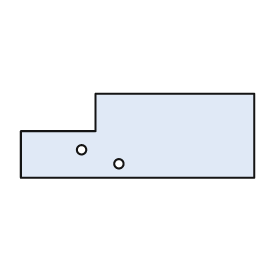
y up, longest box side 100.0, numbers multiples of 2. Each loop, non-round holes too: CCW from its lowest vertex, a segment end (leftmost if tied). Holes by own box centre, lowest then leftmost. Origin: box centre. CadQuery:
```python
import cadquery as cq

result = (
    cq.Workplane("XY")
    .moveTo(-50.0, -18.0)
    .lineTo(50.0, -18.0)
    .lineTo(50.0, 18.0)
    .lineTo(-18.0, 18.0)
    .lineTo(-18.0, 2.0)
    .lineTo(-50.0, 2.0)
    .close()
    .moveTo(-8.0, -12.0)
    .circle(2.0)
    .moveTo(-24.0, -6.0)
    .circle(2.0)
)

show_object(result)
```